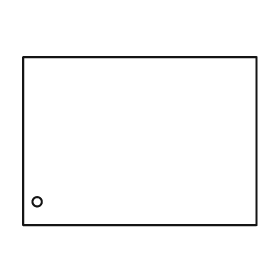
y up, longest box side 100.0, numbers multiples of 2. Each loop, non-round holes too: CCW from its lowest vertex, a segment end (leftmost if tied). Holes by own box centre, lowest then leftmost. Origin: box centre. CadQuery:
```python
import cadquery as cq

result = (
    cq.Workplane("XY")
    .moveTo(-50.0, -36.0)
    .lineTo(50.0, -36.0)
    .lineTo(50.0, 36.0)
    .lineTo(-50.0, 36.0)
    .close()
    .moveTo(-44.0, -26.0)
    .circle(2.0)
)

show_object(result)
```